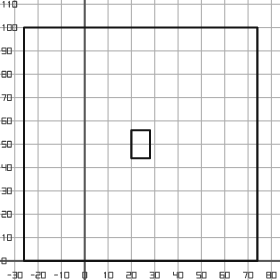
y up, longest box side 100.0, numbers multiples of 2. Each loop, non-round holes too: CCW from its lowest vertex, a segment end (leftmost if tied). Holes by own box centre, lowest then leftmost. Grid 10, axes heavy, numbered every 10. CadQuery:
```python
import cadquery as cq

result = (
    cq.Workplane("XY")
    .moveTo(-26.0, 0.0)
    .lineTo(74.0, 0.0)
    .lineTo(74.0, 100.0)
    .lineTo(-26.0, 100.0)
    .close()
    .moveTo(20.0, 44.0)
    .lineTo(28.0, 44.0)
    .lineTo(28.0, 56.0)
    .lineTo(20.0, 56.0)
    .close()
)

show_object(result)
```